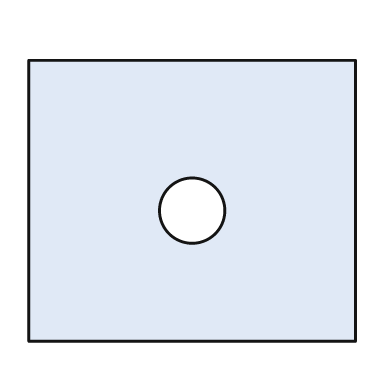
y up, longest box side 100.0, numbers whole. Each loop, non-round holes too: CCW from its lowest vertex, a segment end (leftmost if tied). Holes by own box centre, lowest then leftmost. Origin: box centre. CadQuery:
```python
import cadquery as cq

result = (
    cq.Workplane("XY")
    .moveTo(-50.0, -43.0)
    .lineTo(50.0, -43.0)
    .lineTo(50.0, 43.0)
    .lineTo(-50.0, 43.0)
    .close()
    .moveTo(0.0, -3.0)
    .circle(10.0)
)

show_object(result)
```